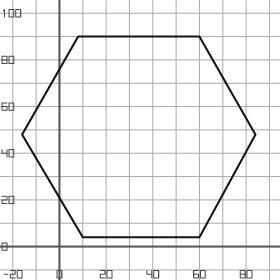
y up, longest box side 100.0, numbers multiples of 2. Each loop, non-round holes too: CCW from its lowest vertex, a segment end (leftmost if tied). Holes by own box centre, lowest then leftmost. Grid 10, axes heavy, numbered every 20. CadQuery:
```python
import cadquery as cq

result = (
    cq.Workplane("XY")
    .moveTo(10.0, 4.0)
    .lineTo(60.0, 4.0)
    .lineTo(84.0, 48.0)
    .lineTo(60.0, 90.0)
    .lineTo(8.0, 90.0)
    .lineTo(-16.0, 48.0)
    .close()
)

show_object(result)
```